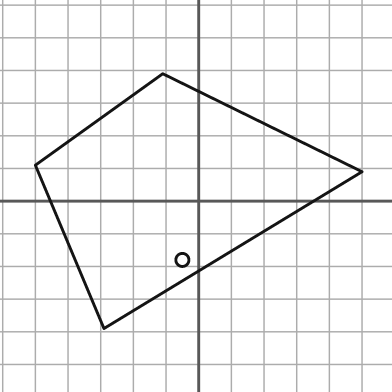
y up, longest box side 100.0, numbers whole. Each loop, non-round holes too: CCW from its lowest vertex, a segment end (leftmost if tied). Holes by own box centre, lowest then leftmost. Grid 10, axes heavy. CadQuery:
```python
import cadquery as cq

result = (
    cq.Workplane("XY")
    .moveTo(-29.0, -39.0)
    .lineTo(50.0, 9.0)
    .lineTo(-11.0, 39.0)
    .lineTo(-50.0, 11.0)
    .close()
    .moveTo(-5.0, -18.0)
    .circle(2.0)
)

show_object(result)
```